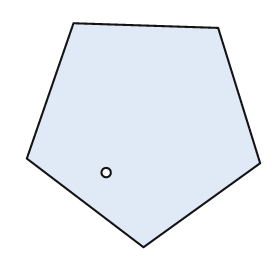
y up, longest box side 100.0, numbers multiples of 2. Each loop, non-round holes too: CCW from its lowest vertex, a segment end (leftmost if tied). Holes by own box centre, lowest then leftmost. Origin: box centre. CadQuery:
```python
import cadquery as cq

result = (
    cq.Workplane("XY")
    .moveTo(0.0, -48.0)
    .lineTo(50.0, -12.0)
    .lineTo(32.0, 46.0)
    .lineTo(-30.0, 48.0)
    .lineTo(-50.0, -10.0)
    .close()
    .moveTo(-16.0, -16.0)
    .circle(2.0)
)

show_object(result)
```